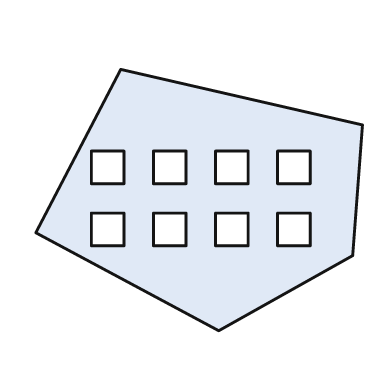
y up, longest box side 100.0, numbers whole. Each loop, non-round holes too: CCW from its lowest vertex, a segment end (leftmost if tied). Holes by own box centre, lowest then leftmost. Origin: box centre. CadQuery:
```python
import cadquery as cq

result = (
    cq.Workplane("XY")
    .moveTo(6.0, -40.0)
    .lineTo(47.0, -17.0)
    .lineTo(50.0, 23.0)
    .lineTo(-24.0, 40.0)
    .lineTo(-50.0, -10.0)
    .close()
    .moveTo(-33.0, -14.0)
    .lineTo(-23.0, -14.0)
    .lineTo(-23.0, -4.0)
    .lineTo(-33.0, -4.0)
    .close()
    .moveTo(-14.0, -14.0)
    .lineTo(-4.0, -14.0)
    .lineTo(-4.0, -4.0)
    .lineTo(-14.0, -4.0)
    .close()
    .moveTo(5.0, -14.0)
    .lineTo(15.0, -14.0)
    .lineTo(15.0, -4.0)
    .lineTo(5.0, -4.0)
    .close()
    .moveTo(24.0, -14.0)
    .lineTo(34.0, -14.0)
    .lineTo(34.0, -4.0)
    .lineTo(24.0, -4.0)
    .close()
    .moveTo(-33.0, 5.0)
    .lineTo(-23.0, 5.0)
    .lineTo(-23.0, 15.0)
    .lineTo(-33.0, 15.0)
    .close()
    .moveTo(-14.0, 5.0)
    .lineTo(-4.0, 5.0)
    .lineTo(-4.0, 15.0)
    .lineTo(-14.0, 15.0)
    .close()
    .moveTo(5.0, 5.0)
    .lineTo(15.0, 5.0)
    .lineTo(15.0, 15.0)
    .lineTo(5.0, 15.0)
    .close()
    .moveTo(24.0, 5.0)
    .lineTo(34.0, 5.0)
    .lineTo(34.0, 15.0)
    .lineTo(24.0, 15.0)
    .close()
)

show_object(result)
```